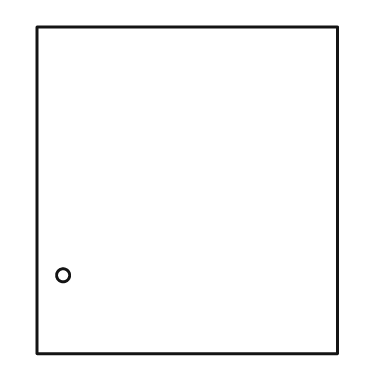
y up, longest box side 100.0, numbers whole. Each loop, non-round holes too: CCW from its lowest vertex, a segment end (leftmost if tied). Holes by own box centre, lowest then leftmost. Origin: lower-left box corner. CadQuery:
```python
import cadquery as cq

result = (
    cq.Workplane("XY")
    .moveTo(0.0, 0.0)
    .lineTo(92.0, 0.0)
    .lineTo(92.0, 100.0)
    .lineTo(0.0, 100.0)
    .close()
    .moveTo(8.0, 24.0)
    .circle(2.0)
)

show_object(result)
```